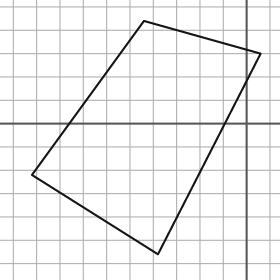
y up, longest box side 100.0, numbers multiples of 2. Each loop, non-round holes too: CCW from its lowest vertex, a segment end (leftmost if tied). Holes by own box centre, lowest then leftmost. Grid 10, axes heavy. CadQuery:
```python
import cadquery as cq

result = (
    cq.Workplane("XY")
    .moveTo(-38.0, -56.0)
    .lineTo(6.0, 30.0)
    .lineTo(-44.0, 44.0)
    .lineTo(-92.0, -22.0)
    .close()
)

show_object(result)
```